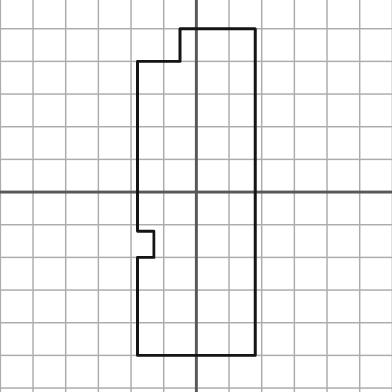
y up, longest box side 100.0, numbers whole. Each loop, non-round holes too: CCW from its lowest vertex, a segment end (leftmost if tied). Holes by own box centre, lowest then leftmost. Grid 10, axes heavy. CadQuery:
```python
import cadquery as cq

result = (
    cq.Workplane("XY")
    .moveTo(-18.0, -50.0)
    .lineTo(18.0, -50.0)
    .lineTo(18.0, 50.0)
    .lineTo(-5.0, 50.0)
    .lineTo(-5.0, 40.0)
    .lineTo(-18.0, 40.0)
    .lineTo(-18.0, -12.0)
    .lineTo(-13.0, -12.0)
    .lineTo(-13.0, -20.0)
    .lineTo(-18.0, -20.0)
    .close()
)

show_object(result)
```